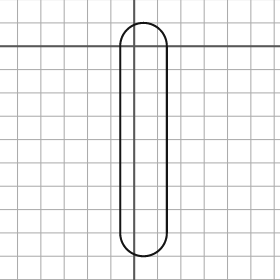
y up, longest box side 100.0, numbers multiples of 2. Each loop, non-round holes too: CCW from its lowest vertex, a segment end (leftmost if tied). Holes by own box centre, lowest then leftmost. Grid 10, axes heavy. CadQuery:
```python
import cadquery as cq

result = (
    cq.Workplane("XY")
    .moveTo(-6.0, -80.0)
    .threePointArc((4.0, -90.0), (14.0, -80.0))
    .lineTo(14.0, 0.0)
    .threePointArc((4.0, 10.0), (-6.0, 0.0))
    .close()
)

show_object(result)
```